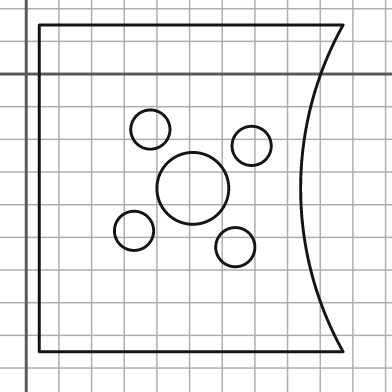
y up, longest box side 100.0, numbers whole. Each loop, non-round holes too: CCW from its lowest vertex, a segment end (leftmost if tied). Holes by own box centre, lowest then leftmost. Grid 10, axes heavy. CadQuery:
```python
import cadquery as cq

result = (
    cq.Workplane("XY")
    .moveTo(4.0, -85.0)
    .lineTo(97.0, -85.0)
    .threePointArc((84.0, -35.0), (97.0, 15.0))
    .lineTo(4.0, 15.0)
    .close()
    .moveTo(64.0, -53.0)
    .circle(6.0)
    .moveTo(33.0, -48.0)
    .circle(6.0)
    .moveTo(51.0, -35.0)
    .circle(11.0)
    .moveTo(69.0, -22.0)
    .circle(6.0)
    .moveTo(38.0, -17.0)
    .circle(6.0)
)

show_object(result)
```